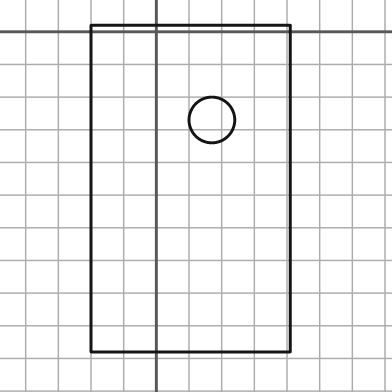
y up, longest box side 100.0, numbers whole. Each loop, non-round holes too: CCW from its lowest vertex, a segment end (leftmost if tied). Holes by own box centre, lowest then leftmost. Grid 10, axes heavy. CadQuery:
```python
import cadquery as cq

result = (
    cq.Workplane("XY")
    .moveTo(-20.0, -98.0)
    .lineTo(41.0, -98.0)
    .lineTo(41.0, 2.0)
    .lineTo(-20.0, 2.0)
    .close()
    .moveTo(17.0, -27.0)
    .circle(7.0)
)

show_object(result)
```